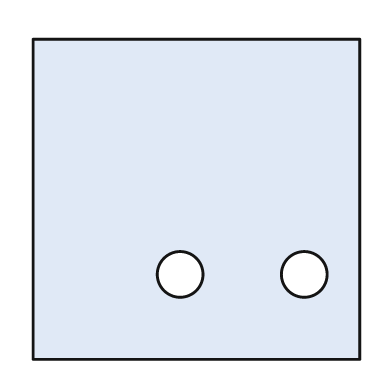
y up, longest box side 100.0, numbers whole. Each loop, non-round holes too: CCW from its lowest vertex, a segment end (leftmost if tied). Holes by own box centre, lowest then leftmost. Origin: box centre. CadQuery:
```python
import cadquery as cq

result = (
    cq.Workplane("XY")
    .moveTo(-50.0, -49.0)
    .lineTo(50.0, -49.0)
    .lineTo(50.0, 49.0)
    .lineTo(-50.0, 49.0)
    .close()
    .moveTo(-5.0, -23.0)
    .circle(7.0)
    .moveTo(33.0, -23.0)
    .circle(7.0)
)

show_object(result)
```